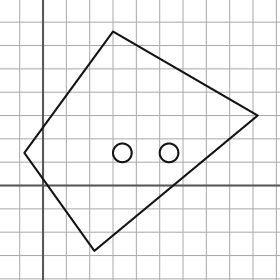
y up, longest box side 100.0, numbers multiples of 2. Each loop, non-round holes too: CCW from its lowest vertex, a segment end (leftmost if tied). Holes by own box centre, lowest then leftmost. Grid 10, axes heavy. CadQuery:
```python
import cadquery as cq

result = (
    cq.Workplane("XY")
    .moveTo(22.0, -28.0)
    .lineTo(92.0, 30.0)
    .lineTo(30.0, 66.0)
    .lineTo(-8.0, 14.0)
    .close()
    .moveTo(34.0, 14.0)
    .circle(4.0)
    .moveTo(54.0, 14.0)
    .circle(4.0)
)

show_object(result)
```